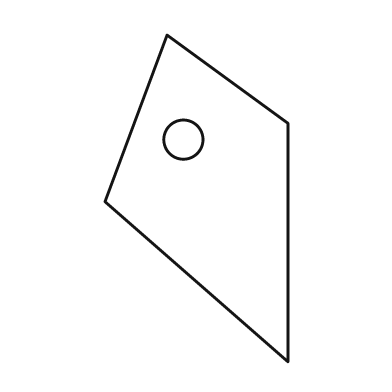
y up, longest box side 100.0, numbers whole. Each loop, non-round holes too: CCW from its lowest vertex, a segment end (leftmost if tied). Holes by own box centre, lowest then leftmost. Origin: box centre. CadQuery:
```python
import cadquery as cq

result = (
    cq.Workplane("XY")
    .moveTo(28.0, -50.0)
    .lineTo(28.0, 23.0)
    .lineTo(-9.0, 50.0)
    .lineTo(-28.0, -1.0)
    .close()
    .moveTo(-4.0, 18.0)
    .circle(6.0)
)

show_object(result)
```